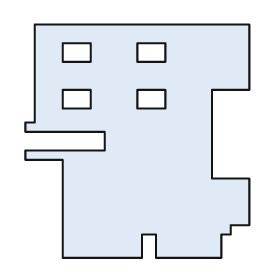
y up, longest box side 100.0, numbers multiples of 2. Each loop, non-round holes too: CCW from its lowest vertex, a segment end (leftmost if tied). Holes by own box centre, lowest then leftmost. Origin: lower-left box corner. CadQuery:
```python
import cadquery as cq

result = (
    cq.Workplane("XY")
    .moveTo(16.0, 0.0)
    .lineTo(50.0, 0.0)
    .lineTo(50.0, 10.0)
    .lineTo(56.0, 10.0)
    .lineTo(56.0, 0.0)
    .lineTo(84.0, 0.0)
    .lineTo(84.0, 10.0)
    .lineTo(88.0, 10.0)
    .lineTo(88.0, 14.0)
    .lineTo(96.0, 14.0)
    .lineTo(96.0, 34.0)
    .lineTo(80.0, 34.0)
    .lineTo(80.0, 72.0)
    .lineTo(96.0, 72.0)
    .lineTo(96.0, 100.0)
    .lineTo(4.0, 100.0)
    .lineTo(4.0, 58.0)
    .lineTo(0.0, 58.0)
    .lineTo(0.0, 54.0)
    .lineTo(34.0, 54.0)
    .lineTo(34.0, 46.0)
    .lineTo(0.0, 46.0)
    .lineTo(0.0, 42.0)
    .lineTo(16.0, 42.0)
    .close()
    .moveTo(16.0, 64.0)
    .lineTo(28.0, 64.0)
    .lineTo(28.0, 72.0)
    .lineTo(16.0, 72.0)
    .close()
    .moveTo(48.0, 64.0)
    .lineTo(60.0, 64.0)
    .lineTo(60.0, 72.0)
    .lineTo(48.0, 72.0)
    .close()
    .moveTo(16.0, 84.0)
    .lineTo(28.0, 84.0)
    .lineTo(28.0, 92.0)
    .lineTo(16.0, 92.0)
    .close()
    .moveTo(48.0, 84.0)
    .lineTo(60.0, 84.0)
    .lineTo(60.0, 92.0)
    .lineTo(48.0, 92.0)
    .close()
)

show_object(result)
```